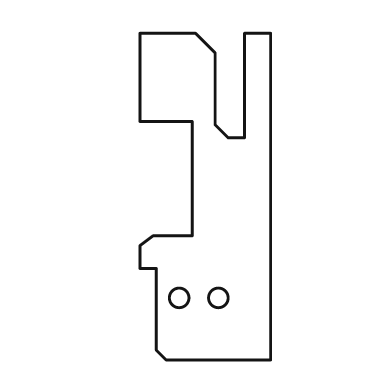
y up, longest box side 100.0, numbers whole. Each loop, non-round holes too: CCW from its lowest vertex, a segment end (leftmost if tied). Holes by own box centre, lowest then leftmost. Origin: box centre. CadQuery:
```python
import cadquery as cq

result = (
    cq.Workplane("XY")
    .moveTo(-12.0, -50.0)
    .lineTo(20.0, -50.0)
    .lineTo(20.0, 50.0)
    .lineTo(12.0, 50.0)
    .lineTo(12.0, 18.0)
    .lineTo(7.0, 18.0)
    .lineTo(3.0, 22.0)
    .lineTo(3.0, 44.0)
    .lineTo(-3.0, 50.0)
    .lineTo(-20.0, 50.0)
    .lineTo(-20.0, 23.0)
    .lineTo(-4.0, 23.0)
    .lineTo(-4.0, -12.0)
    .lineTo(-16.0, -12.0)
    .lineTo(-20.0, -15.0)
    .lineTo(-20.0, -22.0)
    .lineTo(-15.0, -22.0)
    .lineTo(-15.0, -47.0)
    .close()
    .moveTo(-8.0, -31.0)
    .circle(3.0)
    .moveTo(4.0, -31.0)
    .circle(3.0)
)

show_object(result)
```